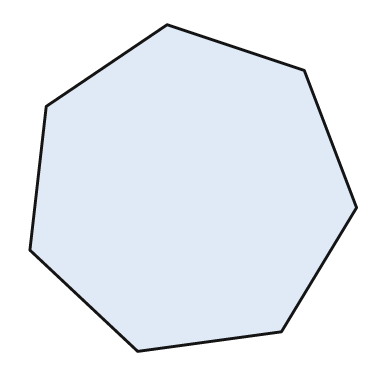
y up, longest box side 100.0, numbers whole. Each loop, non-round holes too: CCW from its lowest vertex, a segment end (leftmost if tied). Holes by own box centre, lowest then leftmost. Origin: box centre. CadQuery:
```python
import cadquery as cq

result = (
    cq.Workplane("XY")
    .moveTo(-17.0, -50.0)
    .lineTo(27.0, -44.0)
    .lineTo(50.0, -6.0)
    .lineTo(34.0, 36.0)
    .lineTo(-8.0, 50.0)
    .lineTo(-45.0, 25.0)
    .lineTo(-50.0, -19.0)
    .close()
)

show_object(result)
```